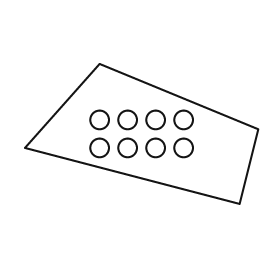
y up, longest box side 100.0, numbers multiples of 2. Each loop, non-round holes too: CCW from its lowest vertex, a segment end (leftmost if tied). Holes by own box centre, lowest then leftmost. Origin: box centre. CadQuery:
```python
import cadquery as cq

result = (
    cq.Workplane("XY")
    .moveTo(42.0, -30.0)
    .lineTo(50.0, 2.0)
    .lineTo(-18.0, 30.0)
    .lineTo(-50.0, -6.0)
    .close()
    .moveTo(-18.0, -6.0)
    .circle(4.0)
    .moveTo(-6.0, -6.0)
    .circle(4.0)
    .moveTo(6.0, -6.0)
    .circle(4.0)
    .moveTo(18.0, -6.0)
    .circle(4.0)
    .moveTo(-18.0, 6.0)
    .circle(4.0)
    .moveTo(-6.0, 6.0)
    .circle(4.0)
    .moveTo(6.0, 6.0)
    .circle(4.0)
    .moveTo(18.0, 6.0)
    .circle(4.0)
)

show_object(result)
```